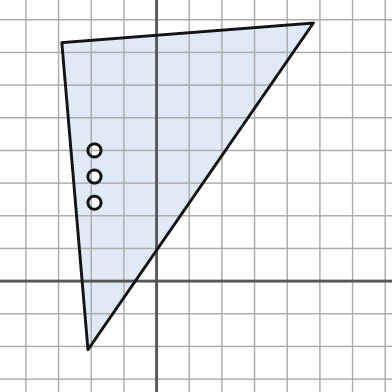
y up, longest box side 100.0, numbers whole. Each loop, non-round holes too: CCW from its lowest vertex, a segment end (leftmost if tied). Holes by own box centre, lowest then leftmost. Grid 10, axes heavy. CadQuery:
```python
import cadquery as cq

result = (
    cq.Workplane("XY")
    .moveTo(-21.0, -21.0)
    .lineTo(48.0, 79.0)
    .lineTo(-29.0, 73.0)
    .close()
    .moveTo(-19.0, 24.0)
    .circle(2.0)
    .moveTo(-19.0, 32.0)
    .circle(2.0)
    .moveTo(-19.0, 40.0)
    .circle(2.0)
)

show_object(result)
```